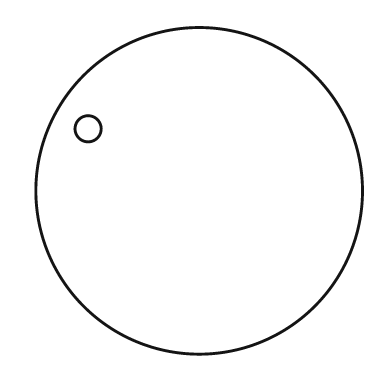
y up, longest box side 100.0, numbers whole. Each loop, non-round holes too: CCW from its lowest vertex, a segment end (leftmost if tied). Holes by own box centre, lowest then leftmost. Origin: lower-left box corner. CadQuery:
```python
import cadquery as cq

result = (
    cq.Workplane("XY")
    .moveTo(50.0, 50.0)
    .circle(50.0)
    .moveTo(16.0, 69.0)
    .circle(4.0)
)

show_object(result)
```